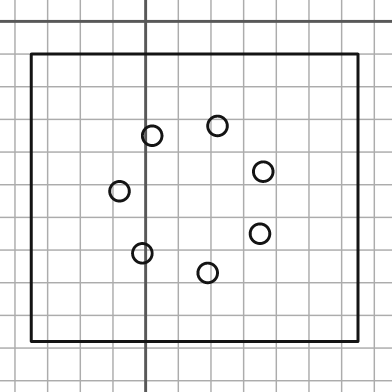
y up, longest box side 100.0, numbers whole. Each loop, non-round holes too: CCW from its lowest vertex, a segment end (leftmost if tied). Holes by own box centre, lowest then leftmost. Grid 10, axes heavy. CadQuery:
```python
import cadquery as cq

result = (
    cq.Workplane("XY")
    .moveTo(-35.0, -98.0)
    .lineTo(65.0, -98.0)
    .lineTo(65.0, -10.0)
    .lineTo(-35.0, -10.0)
    .close()
    .moveTo(19.0, -77.0)
    .circle(3.0)
    .moveTo(-1.0, -71.0)
    .circle(3.0)
    .moveTo(35.0, -65.0)
    .circle(3.0)
    .moveTo(-8.0, -52.0)
    .circle(3.0)
    .moveTo(36.0, -46.0)
    .circle(3.0)
    .moveTo(2.0, -35.0)
    .circle(3.0)
    .moveTo(22.0, -32.0)
    .circle(3.0)
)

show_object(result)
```